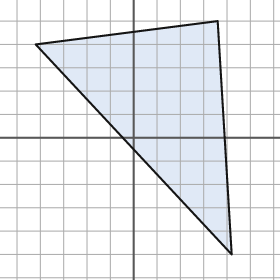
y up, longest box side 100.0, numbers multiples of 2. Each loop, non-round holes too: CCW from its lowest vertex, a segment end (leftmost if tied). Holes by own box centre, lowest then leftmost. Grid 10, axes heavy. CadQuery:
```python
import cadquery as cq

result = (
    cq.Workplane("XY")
    .moveTo(42.0, -50.0)
    .lineTo(36.0, 50.0)
    .lineTo(-42.0, 40.0)
    .close()
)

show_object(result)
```